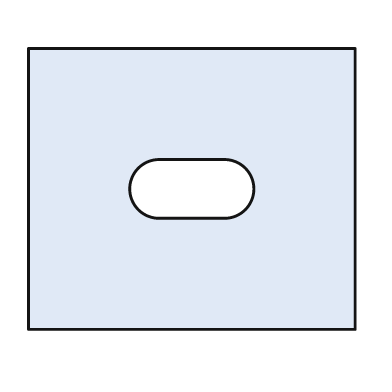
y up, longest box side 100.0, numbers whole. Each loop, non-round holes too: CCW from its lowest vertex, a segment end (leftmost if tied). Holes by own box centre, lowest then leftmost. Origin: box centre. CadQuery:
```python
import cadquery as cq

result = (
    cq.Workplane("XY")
    .moveTo(-50.0, -43.0)
    .lineTo(50.0, -43.0)
    .lineTo(50.0, 43.0)
    .lineTo(-50.0, 43.0)
    .close()
    .moveTo(-10.0, -9.0)
    .lineTo(10.0, -9.0)
    .threePointArc((19.0, 0.0), (10.0, 9.0))
    .lineTo(-10.0, 9.0)
    .threePointArc((-19.0, 0.0), (-10.0, -9.0))
    .close()
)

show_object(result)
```